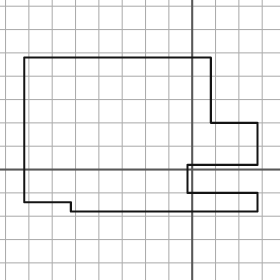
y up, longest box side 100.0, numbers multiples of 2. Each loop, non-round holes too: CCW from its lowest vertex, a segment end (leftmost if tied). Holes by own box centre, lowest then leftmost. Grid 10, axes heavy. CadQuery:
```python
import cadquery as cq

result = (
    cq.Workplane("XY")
    .moveTo(-52.0, -18.0)
    .lineTo(28.0, -18.0)
    .lineTo(28.0, -10.0)
    .lineTo(-2.0, -10.0)
    .lineTo(-2.0, 2.0)
    .lineTo(28.0, 2.0)
    .lineTo(28.0, 20.0)
    .lineTo(8.0, 20.0)
    .lineTo(8.0, 48.0)
    .lineTo(-72.0, 48.0)
    .lineTo(-72.0, -14.0)
    .lineTo(-52.0, -14.0)
    .close()
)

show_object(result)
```